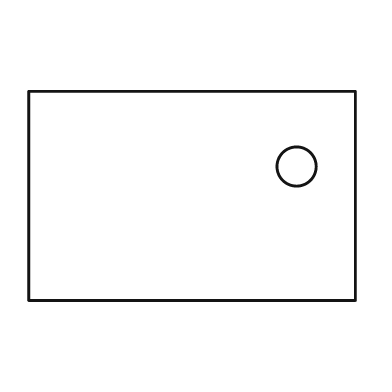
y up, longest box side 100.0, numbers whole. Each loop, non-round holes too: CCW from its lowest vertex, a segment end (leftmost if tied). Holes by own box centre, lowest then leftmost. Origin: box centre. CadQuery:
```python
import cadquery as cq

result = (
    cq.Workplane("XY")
    .moveTo(-50.0, -32.0)
    .lineTo(50.0, -32.0)
    .lineTo(50.0, 32.0)
    .lineTo(-50.0, 32.0)
    .close()
    .moveTo(32.0, 9.0)
    .circle(6.0)
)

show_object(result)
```